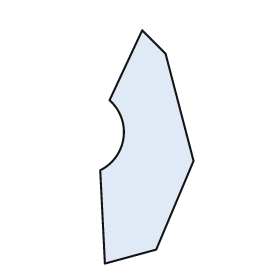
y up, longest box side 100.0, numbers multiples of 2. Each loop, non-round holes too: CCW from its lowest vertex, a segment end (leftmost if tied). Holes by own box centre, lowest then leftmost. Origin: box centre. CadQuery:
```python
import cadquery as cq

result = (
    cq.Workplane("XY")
    .moveTo(-18.0, -50.0)
    .lineTo(4.0, -44.0)
    .lineTo(20.0, -6.0)
    .lineTo(8.0, 40.0)
    .lineTo(-2.0, 50.0)
    .lineTo(-16.0, 20.0)
    .threePointArc((-10.0, 4.0), (-20.0, -10.0))
    .close()
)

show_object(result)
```